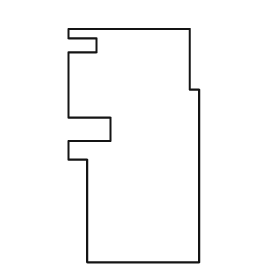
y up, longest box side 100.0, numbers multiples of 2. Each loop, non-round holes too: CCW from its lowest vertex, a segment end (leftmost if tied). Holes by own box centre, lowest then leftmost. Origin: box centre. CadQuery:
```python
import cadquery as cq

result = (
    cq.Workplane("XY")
    .moveTo(-20.0, -50.0)
    .lineTo(28.0, -50.0)
    .lineTo(28.0, 24.0)
    .lineTo(24.0, 24.0)
    .lineTo(24.0, 50.0)
    .lineTo(-28.0, 50.0)
    .lineTo(-28.0, 46.0)
    .lineTo(-16.0, 46.0)
    .lineTo(-16.0, 40.0)
    .lineTo(-28.0, 40.0)
    .lineTo(-28.0, 12.0)
    .lineTo(-10.0, 12.0)
    .lineTo(-10.0, 2.0)
    .lineTo(-28.0, 2.0)
    .lineTo(-28.0, -6.0)
    .lineTo(-20.0, -6.0)
    .close()
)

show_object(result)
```